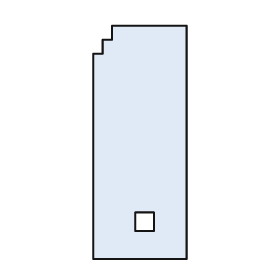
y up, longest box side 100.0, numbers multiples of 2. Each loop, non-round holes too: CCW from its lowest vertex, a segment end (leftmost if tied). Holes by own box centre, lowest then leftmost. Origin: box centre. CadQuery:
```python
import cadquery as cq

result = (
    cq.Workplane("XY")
    .moveTo(-20.0, -50.0)
    .lineTo(20.0, -50.0)
    .lineTo(20.0, 50.0)
    .lineTo(-12.0, 50.0)
    .lineTo(-12.0, 44.0)
    .lineTo(-16.0, 44.0)
    .lineTo(-16.0, 38.0)
    .lineTo(-20.0, 38.0)
    .close()
    .moveTo(-2.0, -38.0)
    .lineTo(6.0, -38.0)
    .lineTo(6.0, -30.0)
    .lineTo(-2.0, -30.0)
    .close()
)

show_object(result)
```